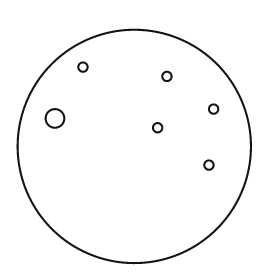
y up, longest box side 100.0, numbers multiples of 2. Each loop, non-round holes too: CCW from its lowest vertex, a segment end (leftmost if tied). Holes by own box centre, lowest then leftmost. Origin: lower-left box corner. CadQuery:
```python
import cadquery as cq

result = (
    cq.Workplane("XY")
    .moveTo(50.0, 50.0)
    .circle(50.0)
    .moveTo(82.0, 42.0)
    .circle(2.0)
    .moveTo(60.0, 58.0)
    .circle(2.0)
    .moveTo(16.0, 62.0)
    .circle(4.0)
    .moveTo(84.0, 66.0)
    .circle(2.0)
    .moveTo(64.0, 80.0)
    .circle(2.0)
    .moveTo(28.0, 84.0)
    .circle(2.0)
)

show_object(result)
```